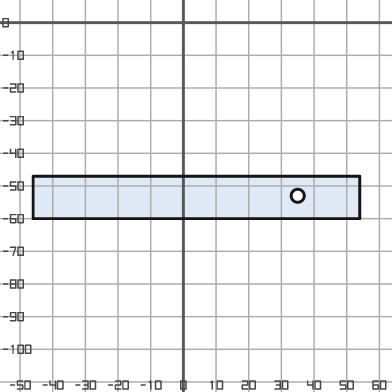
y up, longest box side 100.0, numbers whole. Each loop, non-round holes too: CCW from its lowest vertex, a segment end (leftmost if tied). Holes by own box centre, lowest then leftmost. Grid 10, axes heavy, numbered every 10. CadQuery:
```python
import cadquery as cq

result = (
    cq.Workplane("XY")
    .moveTo(-46.0, -60.0)
    .lineTo(54.0, -60.0)
    .lineTo(54.0, -47.0)
    .lineTo(-46.0, -47.0)
    .close()
    .moveTo(35.0, -53.0)
    .circle(2.0)
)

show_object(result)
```